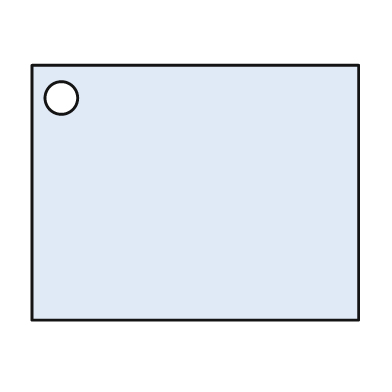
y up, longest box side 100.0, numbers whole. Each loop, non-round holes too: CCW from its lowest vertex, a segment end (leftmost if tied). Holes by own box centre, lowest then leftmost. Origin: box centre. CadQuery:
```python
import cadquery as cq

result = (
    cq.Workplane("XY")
    .moveTo(-50.0, -39.0)
    .lineTo(50.0, -39.0)
    .lineTo(50.0, 39.0)
    .lineTo(-50.0, 39.0)
    .close()
    .moveTo(-41.0, 29.0)
    .circle(5.0)
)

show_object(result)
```